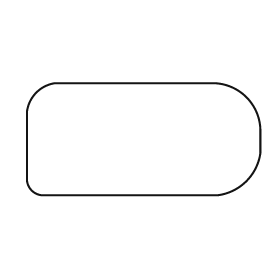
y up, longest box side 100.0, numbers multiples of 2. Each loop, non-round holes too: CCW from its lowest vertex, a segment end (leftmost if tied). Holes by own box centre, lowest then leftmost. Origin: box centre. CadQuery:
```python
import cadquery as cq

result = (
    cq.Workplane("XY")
    .moveTo(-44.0, -24.0)
    .lineTo(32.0, -24.0)
    .threePointArc((44.0, -18.0), (50.0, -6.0))
    .lineTo(50.0, 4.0)
    .threePointArc((44.0, 18.0), (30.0, 24.0))
    .lineTo(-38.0, 24.0)
    .threePointArc((-46.0, 20.0), (-50.0, 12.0))
    .lineTo(-50.0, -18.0)
    .threePointArc((-48.0, -22.0), (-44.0, -24.0))
    .close()
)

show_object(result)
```